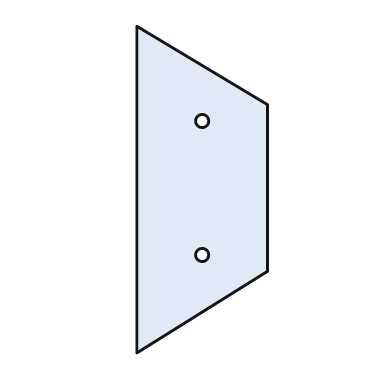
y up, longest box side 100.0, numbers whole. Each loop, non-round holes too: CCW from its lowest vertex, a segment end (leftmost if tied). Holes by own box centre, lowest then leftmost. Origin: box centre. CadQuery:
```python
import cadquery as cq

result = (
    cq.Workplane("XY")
    .moveTo(-20.0, -50.0)
    .lineTo(20.0, -25.0)
    .lineTo(20.0, 26.0)
    .lineTo(-20.0, 50.0)
    .close()
    .moveTo(0.0, -20.0)
    .circle(2.0)
    .moveTo(0.0, 21.0)
    .circle(2.0)
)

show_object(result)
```